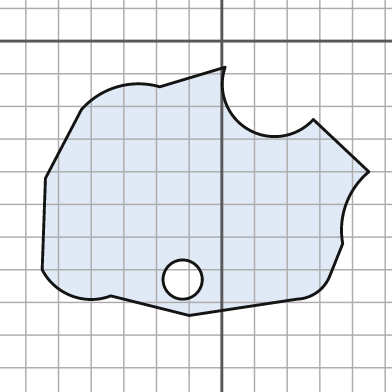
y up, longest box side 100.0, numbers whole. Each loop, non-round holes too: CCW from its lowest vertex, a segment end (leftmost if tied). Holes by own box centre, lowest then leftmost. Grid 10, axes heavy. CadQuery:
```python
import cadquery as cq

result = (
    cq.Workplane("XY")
    .moveTo(-10.0, -84.0)
    .lineTo(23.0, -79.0)
    .threePointArc((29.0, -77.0), (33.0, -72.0))
    .lineTo(37.0, -62.0)
    .threePointArc((38.0, -50.0), (45.0, -40.0))
    .lineTo(28.0, -24.0)
    .threePointArc((8.0, -27.0), (1.0, -8.0))
    .lineTo(-19.0, -14.0)
    .threePointArc((-32.0, -14.0), (-43.0, -21.0))
    .lineTo(-54.0, -42.0)
    .lineTo(-55.0, -70.0)
    .threePointArc((-46.0, -78.0), (-34.0, -78.0))
    .close()
    .moveTo(-12.0, -73.0)
    .circle(6.0)
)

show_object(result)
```